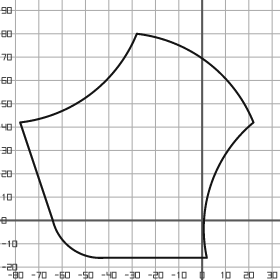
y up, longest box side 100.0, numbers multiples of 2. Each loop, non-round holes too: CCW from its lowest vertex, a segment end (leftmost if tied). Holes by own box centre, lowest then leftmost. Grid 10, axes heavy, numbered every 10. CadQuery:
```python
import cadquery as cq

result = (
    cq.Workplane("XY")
    .moveTo(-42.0, -16.0)
    .lineTo(2.0, -16.0)
    .threePointArc((4.0, 16.0), (22.0, 42.0))
    .threePointArc((2.0, 68.0), (-28.0, 80.0))
    .threePointArc((-48.0, 54.0), (-78.0, 42.0))
    .lineTo(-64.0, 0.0)
    .threePointArc((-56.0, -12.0), (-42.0, -16.0))
    .close()
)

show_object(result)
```